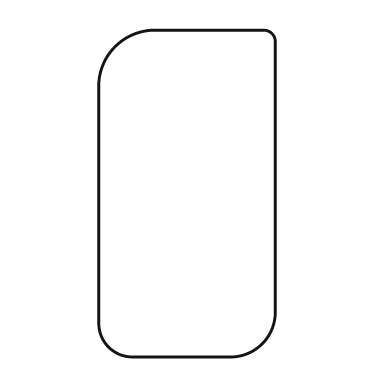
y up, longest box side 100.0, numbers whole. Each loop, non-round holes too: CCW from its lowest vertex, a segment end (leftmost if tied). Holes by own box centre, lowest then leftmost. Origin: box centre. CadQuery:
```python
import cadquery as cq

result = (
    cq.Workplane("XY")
    .moveTo(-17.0, -50.0)
    .lineTo(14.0, -50.0)
    .threePointArc((23.0, -46.0), (27.0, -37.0))
    .lineTo(27.0, 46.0)
    .threePointArc((26.0, 49.0), (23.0, 50.0))
    .lineTo(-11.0, 50.0)
    .threePointArc((-22.0, 45.0), (-27.0, 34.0))
    .lineTo(-27.0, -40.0)
    .threePointArc((-24.0, -47.0), (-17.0, -50.0))
    .close()
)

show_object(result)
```